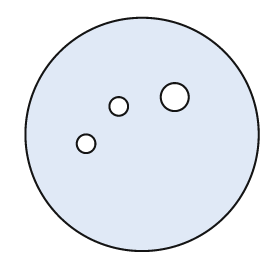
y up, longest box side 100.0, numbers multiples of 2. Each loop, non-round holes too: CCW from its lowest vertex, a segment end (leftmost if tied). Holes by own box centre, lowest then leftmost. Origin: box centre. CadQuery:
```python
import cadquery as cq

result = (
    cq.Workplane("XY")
    .moveTo(0.0, 0.0)
    .circle(50.0)
    .moveTo(-24.0, -4.0)
    .circle(4.0)
    .moveTo(-10.0, 12.0)
    .circle(4.0)
    .moveTo(14.0, 16.0)
    .circle(6.0)
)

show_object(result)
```